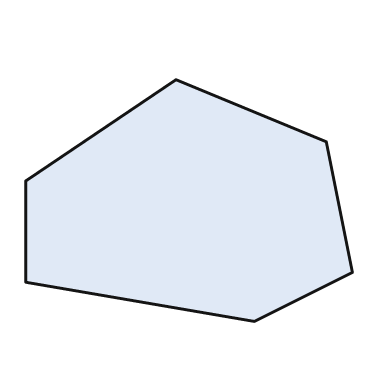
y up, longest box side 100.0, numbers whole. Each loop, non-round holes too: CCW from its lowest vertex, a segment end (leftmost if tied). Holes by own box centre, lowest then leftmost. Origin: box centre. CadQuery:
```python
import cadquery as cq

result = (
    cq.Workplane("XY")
    .moveTo(20.0, -37.0)
    .lineTo(50.0, -22.0)
    .lineTo(42.0, 18.0)
    .lineTo(-4.0, 37.0)
    .lineTo(-50.0, 6.0)
    .lineTo(-50.0, -25.0)
    .close()
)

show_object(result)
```